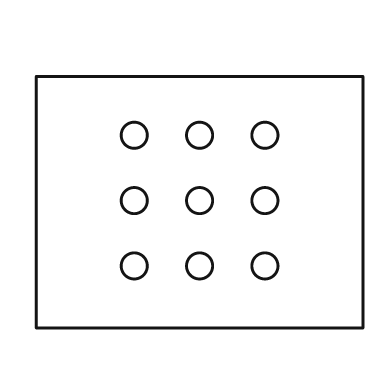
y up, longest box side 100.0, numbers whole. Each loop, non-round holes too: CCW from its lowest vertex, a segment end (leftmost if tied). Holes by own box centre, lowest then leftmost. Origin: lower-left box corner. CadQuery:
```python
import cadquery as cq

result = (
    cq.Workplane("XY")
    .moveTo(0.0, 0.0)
    .lineTo(100.0, 0.0)
    .lineTo(100.0, 77.0)
    .lineTo(0.0, 77.0)
    .close()
    .moveTo(30.0, 19.0)
    .circle(4.0)
    .moveTo(50.0, 19.0)
    .circle(4.0)
    .moveTo(70.0, 19.0)
    .circle(4.0)
    .moveTo(30.0, 39.0)
    .circle(4.0)
    .moveTo(50.0, 39.0)
    .circle(4.0)
    .moveTo(70.0, 39.0)
    .circle(4.0)
    .moveTo(30.0, 59.0)
    .circle(4.0)
    .moveTo(50.0, 59.0)
    .circle(4.0)
    .moveTo(70.0, 59.0)
    .circle(4.0)
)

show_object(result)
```